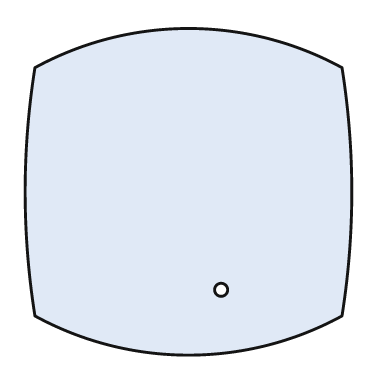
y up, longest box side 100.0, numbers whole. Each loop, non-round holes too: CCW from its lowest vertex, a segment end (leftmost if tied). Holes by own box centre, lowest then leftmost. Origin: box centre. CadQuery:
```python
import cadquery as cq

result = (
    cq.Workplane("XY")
    .moveTo(-47.0, -38.0)
    .threePointArc((0.0, -50.0), (47.0, -38.0))
    .threePointArc((50.0, 0.0), (47.0, 38.0))
    .threePointArc((0.0, 50.0), (-47.0, 38.0))
    .threePointArc((-50.0, 0.0), (-47.0, -38.0))
    .close()
    .moveTo(10.0, -30.0)
    .circle(2.0)
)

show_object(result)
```